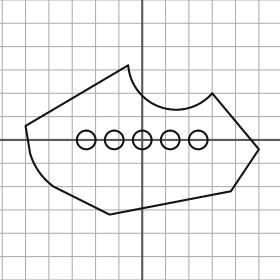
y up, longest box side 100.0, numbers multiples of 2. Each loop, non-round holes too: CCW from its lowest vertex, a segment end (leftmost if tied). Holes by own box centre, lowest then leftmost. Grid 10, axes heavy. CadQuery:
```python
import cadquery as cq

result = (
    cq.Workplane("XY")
    .moveTo(-14.0, -32.0)
    .lineTo(38.0, -22.0)
    .lineTo(50.0, -4.0)
    .lineTo(30.0, 20.0)
    .threePointArc((8.0, 14.0), (-6.0, 32.0))
    .lineTo(-50.0, 6.0)
    .lineTo(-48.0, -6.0)
    .threePointArc((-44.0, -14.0), (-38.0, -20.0))
    .close()
    .moveTo(-24.0, 0.0)
    .circle(4.0)
    .moveTo(-12.0, 0.0)
    .circle(4.0)
    .moveTo(0.0, 0.0)
    .circle(4.0)
    .moveTo(12.0, 0.0)
    .circle(4.0)
    .moveTo(24.0, 0.0)
    .circle(4.0)
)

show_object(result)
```